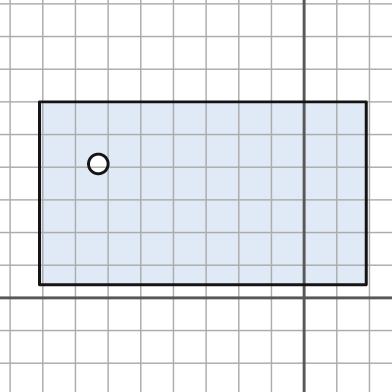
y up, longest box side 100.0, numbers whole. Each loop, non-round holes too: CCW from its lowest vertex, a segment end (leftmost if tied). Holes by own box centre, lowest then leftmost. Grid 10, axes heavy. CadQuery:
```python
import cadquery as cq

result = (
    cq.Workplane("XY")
    .moveTo(-81.0, 4.0)
    .lineTo(19.0, 4.0)
    .lineTo(19.0, 60.0)
    .lineTo(-81.0, 60.0)
    .close()
    .moveTo(-63.0, 41.0)
    .circle(3.0)
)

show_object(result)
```